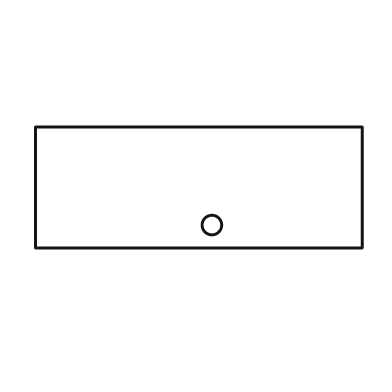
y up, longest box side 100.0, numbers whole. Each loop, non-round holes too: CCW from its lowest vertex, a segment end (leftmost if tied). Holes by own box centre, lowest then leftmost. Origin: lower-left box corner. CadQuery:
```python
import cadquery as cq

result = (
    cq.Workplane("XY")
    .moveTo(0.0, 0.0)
    .lineTo(100.0, 0.0)
    .lineTo(100.0, 37.0)
    .lineTo(0.0, 37.0)
    .close()
    .moveTo(54.0, 7.0)
    .circle(3.0)
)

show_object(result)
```